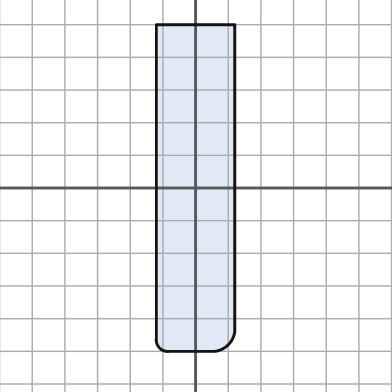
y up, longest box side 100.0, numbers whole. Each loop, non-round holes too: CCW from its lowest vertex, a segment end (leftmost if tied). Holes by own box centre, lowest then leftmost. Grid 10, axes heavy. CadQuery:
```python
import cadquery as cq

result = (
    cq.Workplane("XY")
    .moveTo(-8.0, -50.0)
    .lineTo(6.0, -50.0)
    .threePointArc((10.0, -48.0), (12.0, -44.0))
    .lineTo(12.0, 50.0)
    .lineTo(-12.0, 50.0)
    .lineTo(-12.0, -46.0)
    .threePointArc((-11.0, -49.0), (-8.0, -50.0))
    .close()
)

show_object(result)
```